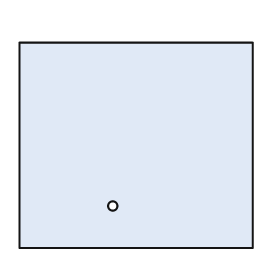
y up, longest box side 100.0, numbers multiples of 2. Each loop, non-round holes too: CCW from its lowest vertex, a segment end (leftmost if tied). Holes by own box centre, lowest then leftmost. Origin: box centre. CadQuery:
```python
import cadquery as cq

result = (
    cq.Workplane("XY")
    .moveTo(-50.0, -44.0)
    .lineTo(50.0, -44.0)
    .lineTo(50.0, 44.0)
    .lineTo(-50.0, 44.0)
    .close()
    .moveTo(-10.0, -26.0)
    .circle(2.0)
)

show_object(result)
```